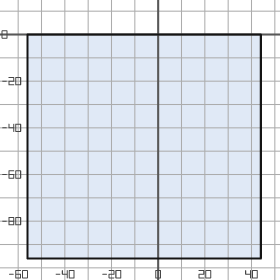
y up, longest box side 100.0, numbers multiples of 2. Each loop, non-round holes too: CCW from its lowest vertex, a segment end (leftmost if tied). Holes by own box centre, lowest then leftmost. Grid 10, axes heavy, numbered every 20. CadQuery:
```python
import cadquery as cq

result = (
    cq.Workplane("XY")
    .moveTo(-56.0, -96.0)
    .lineTo(44.0, -96.0)
    .lineTo(44.0, 0.0)
    .lineTo(-56.0, 0.0)
    .close()
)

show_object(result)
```